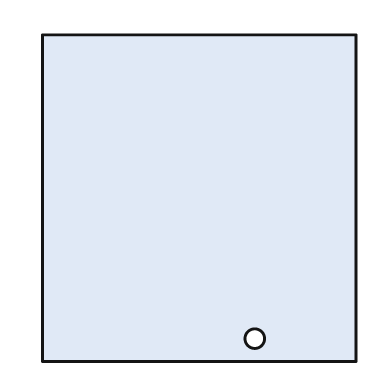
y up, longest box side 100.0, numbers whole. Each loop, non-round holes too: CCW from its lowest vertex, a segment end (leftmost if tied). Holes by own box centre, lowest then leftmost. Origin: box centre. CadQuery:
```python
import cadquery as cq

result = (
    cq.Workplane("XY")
    .moveTo(-48.0, -50.0)
    .lineTo(48.0, -50.0)
    .lineTo(48.0, 50.0)
    .lineTo(-48.0, 50.0)
    .close()
    .moveTo(17.0, -43.0)
    .circle(3.0)
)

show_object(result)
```